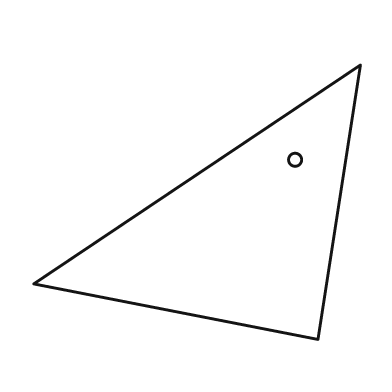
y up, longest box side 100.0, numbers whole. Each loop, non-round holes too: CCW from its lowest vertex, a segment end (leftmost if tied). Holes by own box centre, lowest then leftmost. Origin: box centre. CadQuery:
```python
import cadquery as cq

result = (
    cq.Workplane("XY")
    .moveTo(37.0, -42.0)
    .lineTo(50.0, 42.0)
    .lineTo(-50.0, -25.0)
    .close()
    .moveTo(30.0, 13.0)
    .circle(2.0)
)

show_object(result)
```